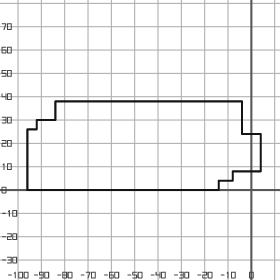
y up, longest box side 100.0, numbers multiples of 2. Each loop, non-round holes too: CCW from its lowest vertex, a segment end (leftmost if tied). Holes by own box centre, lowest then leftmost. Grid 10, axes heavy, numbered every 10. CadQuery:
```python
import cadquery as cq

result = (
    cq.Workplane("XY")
    .moveTo(-96.0, 0.0)
    .lineTo(-14.0, 0.0)
    .lineTo(-14.0, 4.0)
    .lineTo(-8.0, 4.0)
    .lineTo(-8.0, 8.0)
    .lineTo(4.0, 8.0)
    .lineTo(4.0, 24.0)
    .lineTo(-4.0, 24.0)
    .lineTo(-4.0, 38.0)
    .lineTo(-84.0, 38.0)
    .lineTo(-84.0, 30.0)
    .lineTo(-92.0, 30.0)
    .lineTo(-92.0, 26.0)
    .lineTo(-96.0, 26.0)
    .close()
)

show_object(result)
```